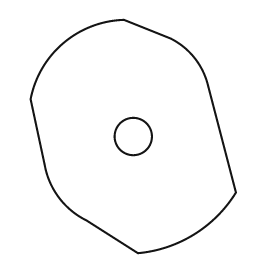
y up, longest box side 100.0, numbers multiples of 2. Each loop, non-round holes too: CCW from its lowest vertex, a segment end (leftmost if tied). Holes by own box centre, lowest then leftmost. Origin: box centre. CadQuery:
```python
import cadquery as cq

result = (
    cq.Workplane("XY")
    .moveTo(2.0, -50.0)
    .threePointArc((26.0, -42.0), (44.0, -24.0))
    .lineTo(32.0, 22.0)
    .threePointArc((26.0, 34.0), (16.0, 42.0))
    .lineTo(-4.0, 50.0)
    .threePointArc((-30.0, 40.0), (-44.0, 16.0))
    .lineTo(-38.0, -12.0)
    .threePointArc((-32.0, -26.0), (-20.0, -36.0))
    .close()
    .moveTo(0.0, 0.0)
    .circle(8.0)
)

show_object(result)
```